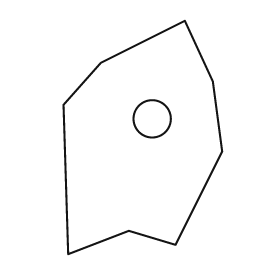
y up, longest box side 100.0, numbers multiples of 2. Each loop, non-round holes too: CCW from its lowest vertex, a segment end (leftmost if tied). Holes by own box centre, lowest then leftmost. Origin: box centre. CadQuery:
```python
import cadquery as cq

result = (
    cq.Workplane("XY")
    .moveTo(-32.0, -50.0)
    .lineTo(-6.0, -40.0)
    .lineTo(14.0, -46.0)
    .lineTo(34.0, -6.0)
    .lineTo(30.0, 24.0)
    .lineTo(18.0, 50.0)
    .lineTo(-18.0, 32.0)
    .lineTo(-34.0, 14.0)
    .close()
    .moveTo(4.0, 8.0)
    .circle(8.0)
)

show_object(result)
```